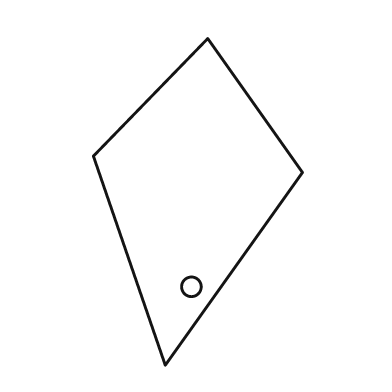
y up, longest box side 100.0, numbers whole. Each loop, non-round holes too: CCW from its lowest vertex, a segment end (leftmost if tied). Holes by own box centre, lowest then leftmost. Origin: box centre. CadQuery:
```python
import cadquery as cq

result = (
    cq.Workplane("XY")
    .moveTo(-10.0, -50.0)
    .lineTo(32.0, 9.0)
    .lineTo(3.0, 50.0)
    .lineTo(-32.0, 14.0)
    .close()
    .moveTo(-2.0, -26.0)
    .circle(3.0)
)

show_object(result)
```